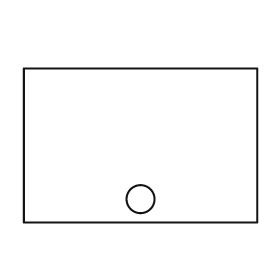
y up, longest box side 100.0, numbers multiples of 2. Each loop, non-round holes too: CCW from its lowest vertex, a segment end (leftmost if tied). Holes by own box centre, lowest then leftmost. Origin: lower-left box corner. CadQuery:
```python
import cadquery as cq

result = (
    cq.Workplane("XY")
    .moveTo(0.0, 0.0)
    .lineTo(100.0, 0.0)
    .lineTo(100.0, 66.0)
    .lineTo(0.0, 66.0)
    .close()
    .moveTo(50.0, 10.0)
    .circle(6.0)
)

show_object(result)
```